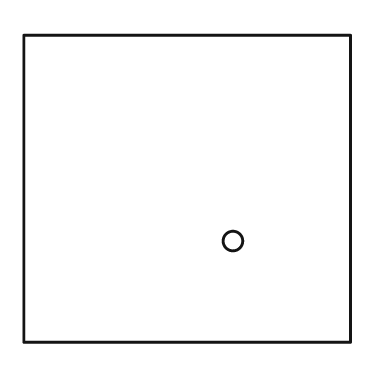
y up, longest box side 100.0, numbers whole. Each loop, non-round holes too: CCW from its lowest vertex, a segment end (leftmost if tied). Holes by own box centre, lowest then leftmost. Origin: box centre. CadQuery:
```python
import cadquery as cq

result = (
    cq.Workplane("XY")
    .moveTo(-50.0, -47.0)
    .lineTo(50.0, -47.0)
    .lineTo(50.0, 47.0)
    .lineTo(-50.0, 47.0)
    .close()
    .moveTo(14.0, -16.0)
    .circle(3.0)
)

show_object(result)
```